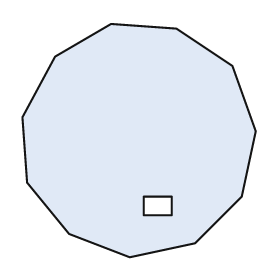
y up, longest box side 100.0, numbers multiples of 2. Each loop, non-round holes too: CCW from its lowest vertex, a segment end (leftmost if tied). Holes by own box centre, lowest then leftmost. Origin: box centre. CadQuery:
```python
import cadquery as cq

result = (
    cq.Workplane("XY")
    .moveTo(-4.0, -50.0)
    .lineTo(24.0, -44.0)
    .lineTo(44.0, -24.0)
    .lineTo(50.0, 4.0)
    .lineTo(40.0, 32.0)
    .lineTo(16.0, 48.0)
    .lineTo(-12.0, 50.0)
    .lineTo(-36.0, 36.0)
    .lineTo(-50.0, 10.0)
    .lineTo(-48.0, -18.0)
    .lineTo(-30.0, -40.0)
    .close()
    .moveTo(2.0, -32.0)
    .lineTo(14.0, -32.0)
    .lineTo(14.0, -24.0)
    .lineTo(2.0, -24.0)
    .close()
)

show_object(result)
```